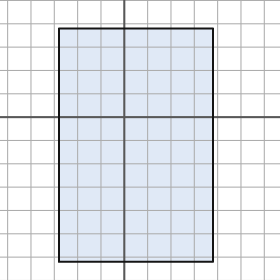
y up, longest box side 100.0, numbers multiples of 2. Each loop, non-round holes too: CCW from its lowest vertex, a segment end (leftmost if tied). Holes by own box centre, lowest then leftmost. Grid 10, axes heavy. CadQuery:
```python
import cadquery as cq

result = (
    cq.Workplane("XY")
    .moveTo(-28.0, -62.0)
    .lineTo(38.0, -62.0)
    .lineTo(38.0, 38.0)
    .lineTo(-28.0, 38.0)
    .close()
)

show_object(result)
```